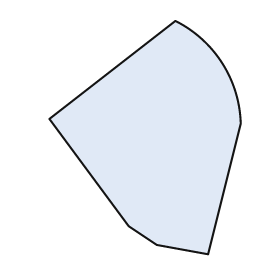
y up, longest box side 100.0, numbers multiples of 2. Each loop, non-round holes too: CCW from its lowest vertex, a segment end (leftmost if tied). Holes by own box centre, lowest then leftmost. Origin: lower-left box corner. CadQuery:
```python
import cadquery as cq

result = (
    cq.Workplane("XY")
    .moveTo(68.0, 0.0)
    .lineTo(82.0, 56.0)
    .threePointArc((74.0, 82.0), (54.0, 100.0))
    .lineTo(0.0, 58.0)
    .lineTo(34.0, 12.0)
    .lineTo(46.0, 4.0)
    .close()
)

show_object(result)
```